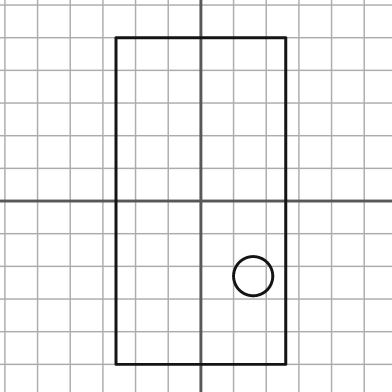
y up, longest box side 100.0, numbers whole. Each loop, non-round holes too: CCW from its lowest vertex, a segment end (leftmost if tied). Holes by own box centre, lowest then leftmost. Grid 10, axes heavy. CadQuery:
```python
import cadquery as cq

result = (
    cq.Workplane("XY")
    .moveTo(-26.0, -50.0)
    .lineTo(26.0, -50.0)
    .lineTo(26.0, 50.0)
    .lineTo(-26.0, 50.0)
    .close()
    .moveTo(16.0, -23.0)
    .circle(6.0)
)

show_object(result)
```